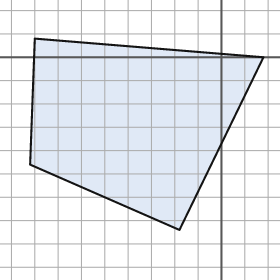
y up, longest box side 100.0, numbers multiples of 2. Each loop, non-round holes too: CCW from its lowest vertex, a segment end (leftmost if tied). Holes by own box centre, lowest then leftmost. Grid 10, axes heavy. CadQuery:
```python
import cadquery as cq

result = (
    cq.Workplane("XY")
    .moveTo(-18.0, -74.0)
    .lineTo(18.0, 0.0)
    .lineTo(-80.0, 8.0)
    .lineTo(-82.0, -46.0)
    .close()
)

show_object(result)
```